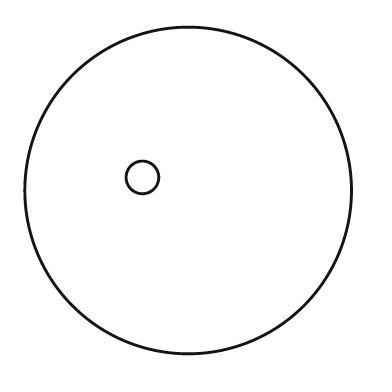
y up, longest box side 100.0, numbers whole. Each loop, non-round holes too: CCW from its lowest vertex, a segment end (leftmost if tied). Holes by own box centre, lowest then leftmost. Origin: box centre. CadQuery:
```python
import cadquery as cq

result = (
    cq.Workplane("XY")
    .moveTo(0.0, 0.0)
    .circle(50.0)
    .moveTo(-14.0, 4.0)
    .circle(5.0)
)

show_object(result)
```